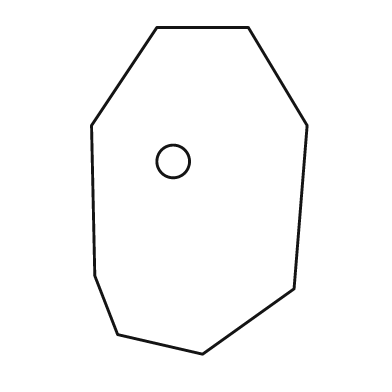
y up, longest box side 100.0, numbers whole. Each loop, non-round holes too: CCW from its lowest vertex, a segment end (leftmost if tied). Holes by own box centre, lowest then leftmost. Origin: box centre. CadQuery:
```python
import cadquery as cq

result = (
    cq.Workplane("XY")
    .moveTo(1.0, -50.0)
    .lineTo(29.0, -30.0)
    .lineTo(33.0, 20.0)
    .lineTo(15.0, 50.0)
    .lineTo(-13.0, 50.0)
    .lineTo(-33.0, 20.0)
    .lineTo(-32.0, -26.0)
    .lineTo(-25.0, -44.0)
    .close()
    .moveTo(-8.0, 9.0)
    .circle(5.0)
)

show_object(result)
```